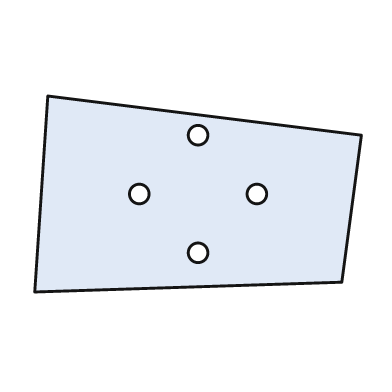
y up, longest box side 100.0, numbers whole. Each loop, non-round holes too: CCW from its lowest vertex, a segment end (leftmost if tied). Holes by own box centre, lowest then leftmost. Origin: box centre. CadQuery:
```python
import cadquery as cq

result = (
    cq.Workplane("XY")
    .moveTo(-50.0, -30.0)
    .lineTo(44.0, -27.0)
    .lineTo(50.0, 18.0)
    .lineTo(-46.0, 30.0)
    .close()
    .moveTo(0.0, -18.0)
    .circle(3.0)
    .moveTo(-18.0, 0.0)
    .circle(3.0)
    .moveTo(18.0, 0.0)
    .circle(3.0)
    .moveTo(0.0, 18.0)
    .circle(3.0)
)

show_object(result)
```